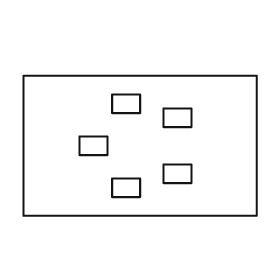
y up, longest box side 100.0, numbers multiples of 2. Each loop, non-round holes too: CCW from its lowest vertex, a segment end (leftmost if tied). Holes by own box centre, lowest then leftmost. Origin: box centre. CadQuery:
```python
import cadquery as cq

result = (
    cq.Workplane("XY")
    .moveTo(-50.0, -30.0)
    .lineTo(50.0, -30.0)
    .lineTo(50.0, 30.0)
    .lineTo(-50.0, 30.0)
    .close()
    .moveTo(-12.0, -22.0)
    .lineTo(0.0, -22.0)
    .lineTo(0.0, -14.0)
    .lineTo(-12.0, -14.0)
    .close()
    .moveTo(10.0, -16.0)
    .lineTo(22.0, -16.0)
    .lineTo(22.0, -8.0)
    .lineTo(10.0, -8.0)
    .close()
    .moveTo(-26.0, -4.0)
    .lineTo(-14.0, -4.0)
    .lineTo(-14.0, 4.0)
    .lineTo(-26.0, 4.0)
    .close()
    .moveTo(10.0, 8.0)
    .lineTo(22.0, 8.0)
    .lineTo(22.0, 16.0)
    .lineTo(10.0, 16.0)
    .close()
    .moveTo(-12.0, 14.0)
    .lineTo(0.0, 14.0)
    .lineTo(0.0, 22.0)
    .lineTo(-12.0, 22.0)
    .close()
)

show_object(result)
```